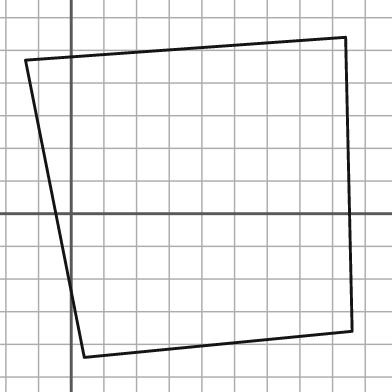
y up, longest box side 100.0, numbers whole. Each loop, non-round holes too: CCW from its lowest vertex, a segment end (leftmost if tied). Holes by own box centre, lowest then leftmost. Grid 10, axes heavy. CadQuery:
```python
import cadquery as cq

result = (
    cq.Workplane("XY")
    .moveTo(4.0, -44.0)
    .lineTo(86.0, -36.0)
    .lineTo(84.0, 54.0)
    .lineTo(-14.0, 47.0)
    .close()
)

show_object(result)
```